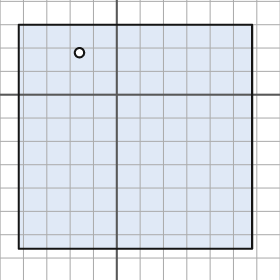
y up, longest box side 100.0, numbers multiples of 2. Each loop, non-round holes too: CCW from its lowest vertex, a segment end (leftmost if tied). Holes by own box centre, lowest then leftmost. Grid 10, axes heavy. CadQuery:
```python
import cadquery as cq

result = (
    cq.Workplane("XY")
    .moveTo(-42.0, -66.0)
    .lineTo(58.0, -66.0)
    .lineTo(58.0, 30.0)
    .lineTo(-42.0, 30.0)
    .close()
    .moveTo(-16.0, 18.0)
    .circle(2.0)
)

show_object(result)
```